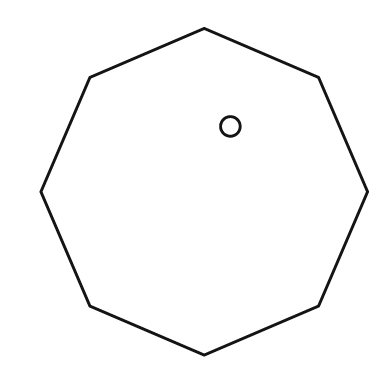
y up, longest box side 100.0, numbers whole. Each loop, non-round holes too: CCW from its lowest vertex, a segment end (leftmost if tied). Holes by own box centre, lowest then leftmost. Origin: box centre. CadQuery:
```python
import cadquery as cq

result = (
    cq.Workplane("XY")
    .moveTo(0.0, -50.0)
    .lineTo(35.0, -35.0)
    .lineTo(50.0, 0.0)
    .lineTo(35.0, 35.0)
    .lineTo(0.0, 50.0)
    .lineTo(-35.0, 35.0)
    .lineTo(-50.0, 0.0)
    .lineTo(-35.0, -35.0)
    .close()
    .moveTo(8.0, 20.0)
    .circle(3.0)
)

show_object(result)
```